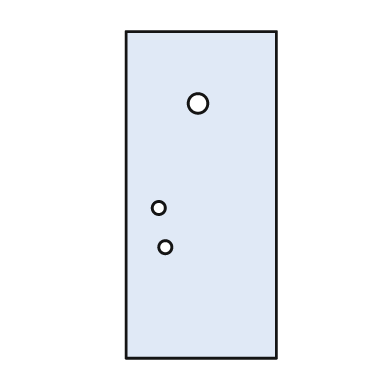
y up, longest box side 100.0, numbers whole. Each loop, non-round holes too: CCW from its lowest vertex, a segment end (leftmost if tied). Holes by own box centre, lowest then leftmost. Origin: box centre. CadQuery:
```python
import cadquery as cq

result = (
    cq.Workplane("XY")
    .moveTo(-23.0, -50.0)
    .lineTo(23.0, -50.0)
    .lineTo(23.0, 50.0)
    .lineTo(-23.0, 50.0)
    .close()
    .moveTo(-11.0, -16.0)
    .circle(2.0)
    .moveTo(-13.0, -4.0)
    .circle(2.0)
    .moveTo(-1.0, 28.0)
    .circle(3.0)
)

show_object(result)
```